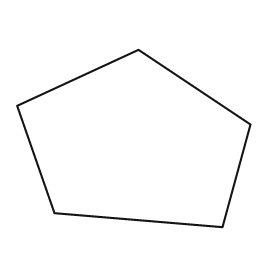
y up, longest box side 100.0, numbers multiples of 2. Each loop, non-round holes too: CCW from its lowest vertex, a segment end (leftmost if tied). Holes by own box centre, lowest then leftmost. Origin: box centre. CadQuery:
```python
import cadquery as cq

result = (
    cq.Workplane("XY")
    .moveTo(38.0, -38.0)
    .lineTo(50.0, 6.0)
    .lineTo(2.0, 38.0)
    .lineTo(-50.0, 14.0)
    .lineTo(-34.0, -32.0)
    .close()
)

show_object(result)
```